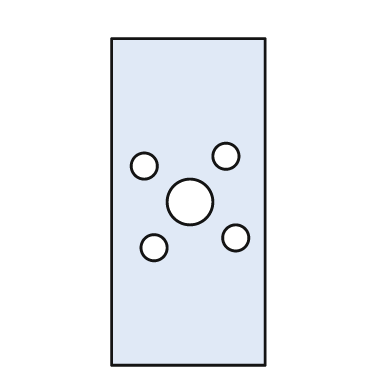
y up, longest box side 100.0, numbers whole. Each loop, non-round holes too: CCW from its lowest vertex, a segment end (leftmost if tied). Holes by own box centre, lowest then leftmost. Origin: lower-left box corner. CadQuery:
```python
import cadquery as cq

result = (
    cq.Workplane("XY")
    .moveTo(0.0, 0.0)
    .lineTo(47.0, 0.0)
    .lineTo(47.0, 100.0)
    .lineTo(0.0, 100.0)
    .close()
    .moveTo(13.0, 36.0)
    .circle(4.0)
    .moveTo(38.0, 39.0)
    .circle(4.0)
    .moveTo(24.0, 50.0)
    .circle(7.0)
    .moveTo(10.0, 61.0)
    .circle(4.0)
    .moveTo(35.0, 64.0)
    .circle(4.0)
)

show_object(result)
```